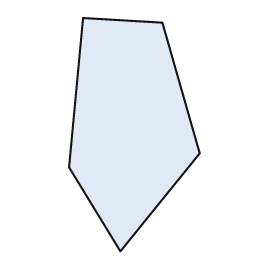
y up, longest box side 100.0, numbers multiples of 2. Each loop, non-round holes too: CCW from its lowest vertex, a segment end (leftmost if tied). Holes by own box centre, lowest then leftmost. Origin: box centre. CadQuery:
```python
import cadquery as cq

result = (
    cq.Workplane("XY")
    .moveTo(-6.0, -50.0)
    .lineTo(28.0, -8.0)
    .lineTo(12.0, 48.0)
    .lineTo(-22.0, 50.0)
    .lineTo(-28.0, -14.0)
    .close()
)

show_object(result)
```